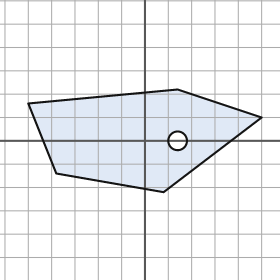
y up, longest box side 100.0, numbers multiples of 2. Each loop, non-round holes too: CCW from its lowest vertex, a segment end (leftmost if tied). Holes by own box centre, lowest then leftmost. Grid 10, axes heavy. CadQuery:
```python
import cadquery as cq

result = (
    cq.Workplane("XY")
    .moveTo(8.0, -22.0)
    .lineTo(50.0, 10.0)
    .lineTo(14.0, 22.0)
    .lineTo(-50.0, 16.0)
    .lineTo(-38.0, -14.0)
    .close()
    .moveTo(14.0, 0.0)
    .circle(4.0)
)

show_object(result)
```